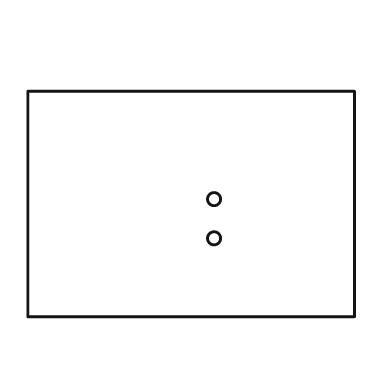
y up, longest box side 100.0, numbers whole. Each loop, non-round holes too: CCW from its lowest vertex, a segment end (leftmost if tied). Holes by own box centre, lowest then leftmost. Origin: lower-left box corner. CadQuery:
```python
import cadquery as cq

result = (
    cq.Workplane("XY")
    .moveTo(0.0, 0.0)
    .lineTo(100.0, 0.0)
    .lineTo(100.0, 69.0)
    .lineTo(0.0, 69.0)
    .close()
    .moveTo(57.0, 24.0)
    .circle(2.0)
    .moveTo(57.0, 36.0)
    .circle(2.0)
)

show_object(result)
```